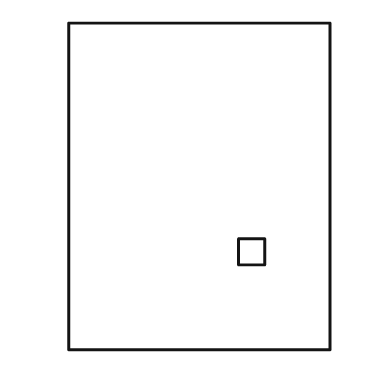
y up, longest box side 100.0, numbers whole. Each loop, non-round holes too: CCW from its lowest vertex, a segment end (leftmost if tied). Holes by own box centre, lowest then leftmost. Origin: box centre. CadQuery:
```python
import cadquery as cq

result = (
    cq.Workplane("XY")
    .moveTo(-40.0, -50.0)
    .lineTo(40.0, -50.0)
    .lineTo(40.0, 50.0)
    .lineTo(-40.0, 50.0)
    .close()
    .moveTo(12.0, -24.0)
    .lineTo(20.0, -24.0)
    .lineTo(20.0, -16.0)
    .lineTo(12.0, -16.0)
    .close()
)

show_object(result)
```